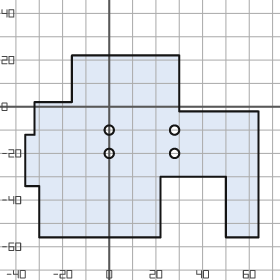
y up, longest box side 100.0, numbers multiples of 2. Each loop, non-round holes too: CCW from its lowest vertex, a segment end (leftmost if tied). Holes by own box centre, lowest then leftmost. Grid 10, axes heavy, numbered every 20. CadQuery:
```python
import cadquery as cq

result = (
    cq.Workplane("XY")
    .moveTo(-30.0, -56.0)
    .lineTo(22.0, -56.0)
    .lineTo(22.0, -30.0)
    .lineTo(50.0, -30.0)
    .lineTo(50.0, -56.0)
    .lineTo(64.0, -56.0)
    .lineTo(64.0, -2.0)
    .lineTo(30.0, -2.0)
    .lineTo(30.0, 22.0)
    .lineTo(-16.0, 22.0)
    .lineTo(-16.0, 2.0)
    .lineTo(-32.0, 2.0)
    .lineTo(-32.0, -12.0)
    .lineTo(-36.0, -12.0)
    .lineTo(-36.0, -34.0)
    .lineTo(-30.0, -34.0)
    .close()
    .moveTo(0.0, -20.0)
    .circle(2.0)
    .moveTo(28.0, -20.0)
    .circle(2.0)
    .moveTo(0.0, -10.0)
    .circle(2.0)
    .moveTo(28.0, -10.0)
    .circle(2.0)
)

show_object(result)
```